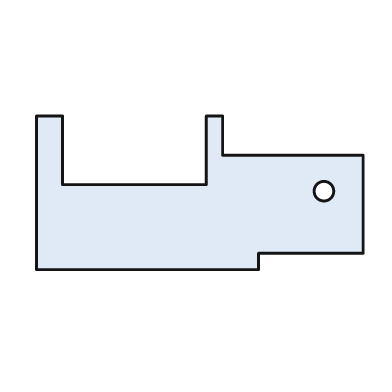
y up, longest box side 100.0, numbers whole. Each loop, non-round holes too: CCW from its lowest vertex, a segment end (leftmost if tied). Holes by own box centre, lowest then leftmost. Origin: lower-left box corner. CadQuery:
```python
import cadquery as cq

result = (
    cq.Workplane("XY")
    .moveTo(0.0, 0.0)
    .lineTo(68.0, 0.0)
    .lineTo(68.0, 5.0)
    .lineTo(100.0, 5.0)
    .lineTo(100.0, 35.0)
    .lineTo(57.0, 35.0)
    .lineTo(57.0, 47.0)
    .lineTo(52.0, 47.0)
    .lineTo(52.0, 26.0)
    .lineTo(8.0, 26.0)
    .lineTo(8.0, 47.0)
    .lineTo(0.0, 47.0)
    .close()
    .moveTo(88.0, 24.0)
    .circle(3.0)
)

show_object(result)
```